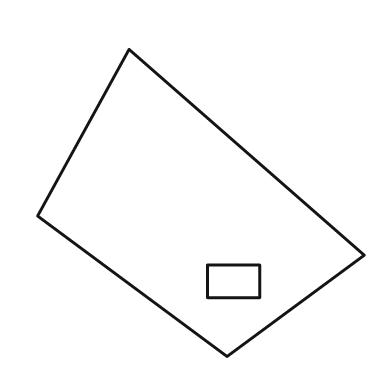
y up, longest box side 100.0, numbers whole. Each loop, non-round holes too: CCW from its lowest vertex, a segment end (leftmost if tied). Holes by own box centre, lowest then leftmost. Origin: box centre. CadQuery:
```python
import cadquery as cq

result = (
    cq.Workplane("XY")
    .moveTo(8.0, -47.0)
    .lineTo(50.0, -16.0)
    .lineTo(-22.0, 47.0)
    .lineTo(-50.0, -4.0)
    .close()
    .moveTo(2.0, -29.0)
    .lineTo(18.0, -29.0)
    .lineTo(18.0, -19.0)
    .lineTo(2.0, -19.0)
    .close()
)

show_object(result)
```